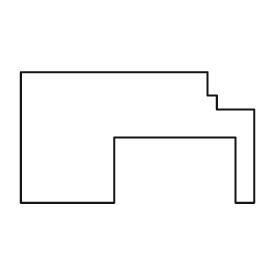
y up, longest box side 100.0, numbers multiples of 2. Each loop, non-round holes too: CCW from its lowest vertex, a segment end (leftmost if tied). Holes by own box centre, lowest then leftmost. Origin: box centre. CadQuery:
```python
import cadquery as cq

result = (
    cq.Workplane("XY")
    .moveTo(-50.0, -28.0)
    .lineTo(-10.0, -28.0)
    .lineTo(-10.0, 0.0)
    .lineTo(42.0, 0.0)
    .lineTo(42.0, -28.0)
    .lineTo(50.0, -28.0)
    .lineTo(50.0, 12.0)
    .lineTo(34.0, 12.0)
    .lineTo(34.0, 18.0)
    .lineTo(30.0, 18.0)
    .lineTo(30.0, 28.0)
    .lineTo(-50.0, 28.0)
    .close()
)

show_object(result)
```